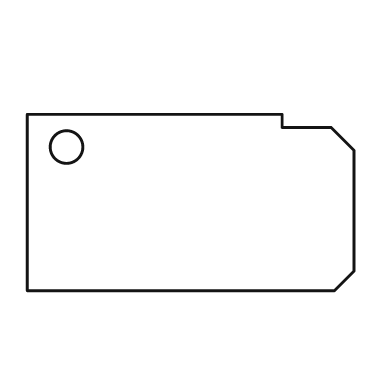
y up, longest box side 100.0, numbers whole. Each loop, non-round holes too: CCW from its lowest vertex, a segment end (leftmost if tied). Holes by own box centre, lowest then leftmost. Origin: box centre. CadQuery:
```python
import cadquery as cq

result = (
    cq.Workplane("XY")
    .moveTo(-50.0, -27.0)
    .lineTo(44.0, -27.0)
    .lineTo(50.0, -21.0)
    .lineTo(50.0, 16.0)
    .lineTo(43.0, 23.0)
    .lineTo(28.0, 23.0)
    .lineTo(28.0, 27.0)
    .lineTo(-50.0, 27.0)
    .close()
    .moveTo(-38.0, 17.0)
    .circle(5.0)
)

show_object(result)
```